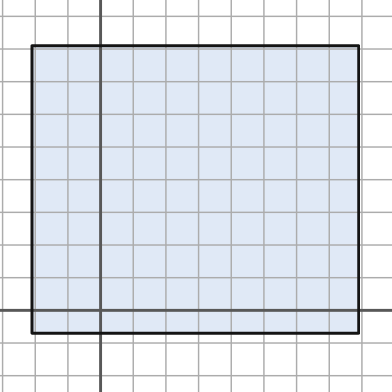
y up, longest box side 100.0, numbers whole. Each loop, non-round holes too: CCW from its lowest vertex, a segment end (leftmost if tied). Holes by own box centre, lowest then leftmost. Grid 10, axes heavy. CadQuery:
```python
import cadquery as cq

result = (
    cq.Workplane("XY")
    .moveTo(-21.0, -7.0)
    .lineTo(79.0, -7.0)
    .lineTo(79.0, 81.0)
    .lineTo(-21.0, 81.0)
    .close()
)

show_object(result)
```